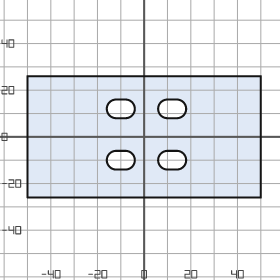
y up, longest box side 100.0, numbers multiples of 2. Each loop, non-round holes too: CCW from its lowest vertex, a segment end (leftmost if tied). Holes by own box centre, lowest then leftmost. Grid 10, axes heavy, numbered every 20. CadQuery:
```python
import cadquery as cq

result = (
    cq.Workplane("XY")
    .moveTo(-50.0, -26.0)
    .lineTo(50.0, -26.0)
    .lineTo(50.0, 26.0)
    .lineTo(-50.0, 26.0)
    .close()
    .moveTo(-12.0, -14.0)
    .lineTo(-8.0, -14.0)
    .threePointArc((-4.0, -10.0), (-8.0, -6.0))
    .lineTo(-12.0, -6.0)
    .threePointArc((-16.0, -10.0), (-12.0, -14.0))
    .close()
    .moveTo(10.0, -14.0)
    .lineTo(14.0, -14.0)
    .threePointArc((18.0, -10.0), (14.0, -6.0))
    .lineTo(10.0, -6.0)
    .threePointArc((6.0, -10.0), (10.0, -14.0))
    .close()
    .moveTo(-12.0, 8.0)
    .lineTo(-8.0, 8.0)
    .threePointArc((-4.0, 12.0), (-8.0, 16.0))
    .lineTo(-12.0, 16.0)
    .threePointArc((-16.0, 12.0), (-12.0, 8.0))
    .close()
    .moveTo(10.0, 8.0)
    .lineTo(14.0, 8.0)
    .threePointArc((18.0, 12.0), (14.0, 16.0))
    .lineTo(10.0, 16.0)
    .threePointArc((6.0, 12.0), (10.0, 8.0))
    .close()
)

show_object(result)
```